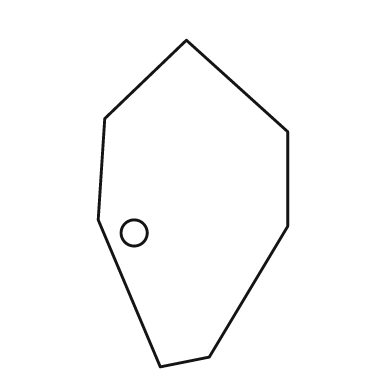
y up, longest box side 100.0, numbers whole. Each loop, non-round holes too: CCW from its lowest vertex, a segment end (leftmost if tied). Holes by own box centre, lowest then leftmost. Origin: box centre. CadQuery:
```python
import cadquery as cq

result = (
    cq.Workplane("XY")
    .moveTo(-10.0, -50.0)
    .lineTo(5.0, -47.0)
    .lineTo(29.0, -7.0)
    .lineTo(29.0, 22.0)
    .lineTo(-2.0, 50.0)
    .lineTo(-27.0, 26.0)
    .lineTo(-29.0, -5.0)
    .close()
    .moveTo(-18.0, -9.0)
    .circle(4.0)
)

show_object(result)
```